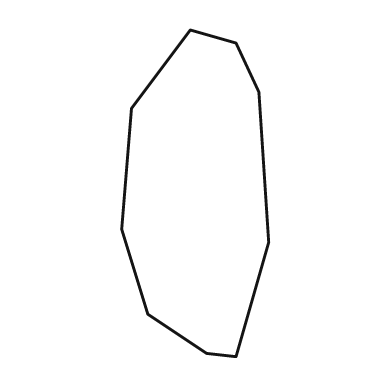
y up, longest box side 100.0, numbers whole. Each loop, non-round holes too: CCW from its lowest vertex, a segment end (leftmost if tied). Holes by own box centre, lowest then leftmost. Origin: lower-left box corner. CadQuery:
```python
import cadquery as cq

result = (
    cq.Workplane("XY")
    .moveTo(35.0, 0.0)
    .lineTo(45.0, 35.0)
    .lineTo(42.0, 81.0)
    .lineTo(35.0, 96.0)
    .lineTo(21.0, 100.0)
    .lineTo(3.0, 76.0)
    .lineTo(0.0, 39.0)
    .lineTo(8.0, 13.0)
    .lineTo(26.0, 1.0)
    .close()
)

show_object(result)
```